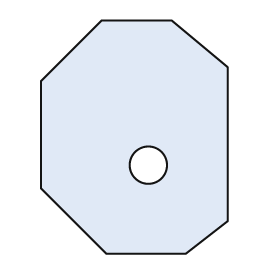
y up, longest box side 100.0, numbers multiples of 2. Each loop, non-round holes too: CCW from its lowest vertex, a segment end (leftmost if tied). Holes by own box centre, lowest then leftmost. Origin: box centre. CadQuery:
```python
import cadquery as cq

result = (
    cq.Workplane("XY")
    .moveTo(-12.0, -50.0)
    .lineTo(22.0, -50.0)
    .lineTo(40.0, -36.0)
    .lineTo(40.0, 30.0)
    .lineTo(16.0, 50.0)
    .lineTo(-14.0, 50.0)
    .lineTo(-40.0, 24.0)
    .lineTo(-40.0, -22.0)
    .close()
    .moveTo(6.0, -12.0)
    .circle(8.0)
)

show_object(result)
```